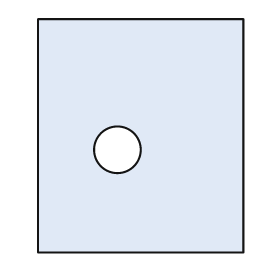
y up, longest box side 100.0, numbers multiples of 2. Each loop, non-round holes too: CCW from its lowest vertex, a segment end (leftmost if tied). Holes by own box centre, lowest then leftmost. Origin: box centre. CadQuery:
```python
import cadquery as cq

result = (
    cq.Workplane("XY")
    .moveTo(-44.0, -50.0)
    .lineTo(44.0, -50.0)
    .lineTo(44.0, 50.0)
    .lineTo(-44.0, 50.0)
    .close()
    .moveTo(-10.0, -6.0)
    .circle(10.0)
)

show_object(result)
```